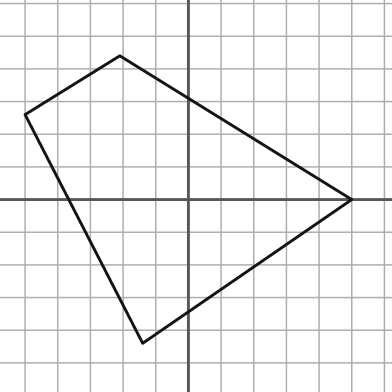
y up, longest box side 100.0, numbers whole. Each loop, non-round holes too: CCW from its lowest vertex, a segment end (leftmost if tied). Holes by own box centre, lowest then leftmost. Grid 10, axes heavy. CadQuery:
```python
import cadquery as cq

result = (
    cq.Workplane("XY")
    .moveTo(-14.0, -44.0)
    .lineTo(50.0, 0.0)
    .lineTo(-21.0, 44.0)
    .lineTo(-50.0, 26.0)
    .close()
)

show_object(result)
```